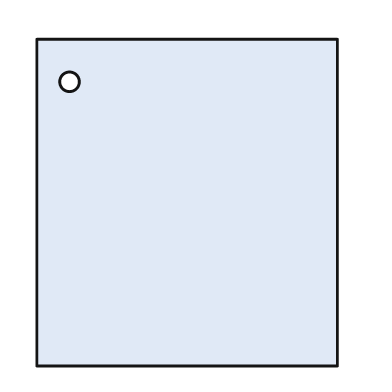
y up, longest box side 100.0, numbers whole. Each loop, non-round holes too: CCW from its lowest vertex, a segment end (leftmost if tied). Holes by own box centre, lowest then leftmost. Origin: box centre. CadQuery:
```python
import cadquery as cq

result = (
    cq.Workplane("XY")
    .moveTo(-46.0, -50.0)
    .lineTo(46.0, -50.0)
    .lineTo(46.0, 50.0)
    .lineTo(-46.0, 50.0)
    .close()
    .moveTo(-36.0, 37.0)
    .circle(3.0)
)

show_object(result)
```